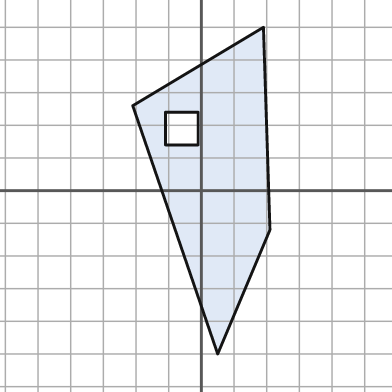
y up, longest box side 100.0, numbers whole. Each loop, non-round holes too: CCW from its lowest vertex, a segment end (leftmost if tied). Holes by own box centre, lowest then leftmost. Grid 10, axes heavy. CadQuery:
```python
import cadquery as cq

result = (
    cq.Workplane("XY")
    .moveTo(5.0, -50.0)
    .lineTo(21.0, -12.0)
    .lineTo(19.0, 50.0)
    .lineTo(-21.0, 26.0)
    .close()
    .moveTo(-11.0, 14.0)
    .lineTo(-1.0, 14.0)
    .lineTo(-1.0, 24.0)
    .lineTo(-11.0, 24.0)
    .close()
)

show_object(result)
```